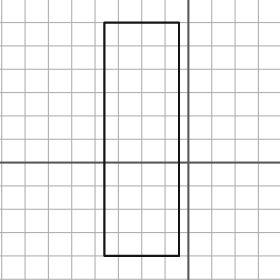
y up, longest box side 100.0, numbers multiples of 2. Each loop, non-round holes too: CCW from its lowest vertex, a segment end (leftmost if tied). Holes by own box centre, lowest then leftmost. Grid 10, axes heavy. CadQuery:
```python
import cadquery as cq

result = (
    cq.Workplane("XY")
    .moveTo(-36.0, -40.0)
    .lineTo(-4.0, -40.0)
    .lineTo(-4.0, 60.0)
    .lineTo(-36.0, 60.0)
    .close()
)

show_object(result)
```